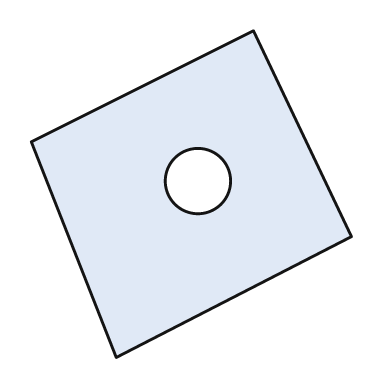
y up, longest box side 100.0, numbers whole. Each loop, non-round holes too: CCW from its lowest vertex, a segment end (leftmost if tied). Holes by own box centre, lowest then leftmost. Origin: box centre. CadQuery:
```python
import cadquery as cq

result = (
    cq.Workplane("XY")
    .moveTo(-23.0, -50.0)
    .lineTo(49.0, -13.0)
    .lineTo(19.0, 50.0)
    .lineTo(-49.0, 16.0)
    .close()
    .moveTo(2.0, 4.0)
    .circle(10.0)
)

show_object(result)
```